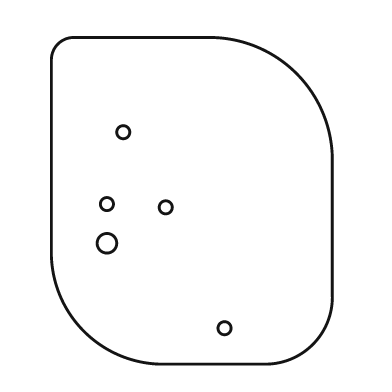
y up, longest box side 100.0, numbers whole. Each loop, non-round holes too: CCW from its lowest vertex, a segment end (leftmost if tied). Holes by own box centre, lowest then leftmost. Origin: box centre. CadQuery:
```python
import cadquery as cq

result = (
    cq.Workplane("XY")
    .moveTo(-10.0, -50.0)
    .lineTo(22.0, -50.0)
    .threePointArc((37.0, -44.0), (43.0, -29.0))
    .lineTo(43.0, 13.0)
    .threePointArc((32.0, 39.0), (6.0, 50.0))
    .lineTo(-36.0, 50.0)
    .threePointArc((-41.0, 48.0), (-43.0, 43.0))
    .lineTo(-43.0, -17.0)
    .threePointArc((-33.0, -40.0), (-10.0, -50.0))
    .close()
    .moveTo(10.0, -39.0)
    .circle(2.0)
    .moveTo(-26.0, -13.0)
    .circle(3.0)
    .moveTo(-8.0, -2.0)
    .circle(2.0)
    .moveTo(-26.0, -1.0)
    .circle(2.0)
    .moveTo(-21.0, 21.0)
    .circle(2.0)
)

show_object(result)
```